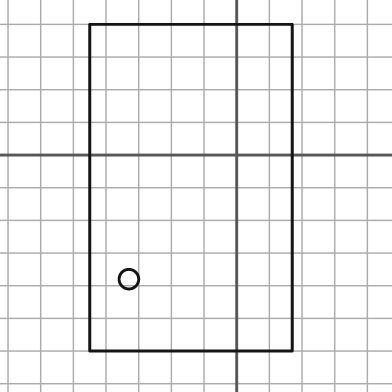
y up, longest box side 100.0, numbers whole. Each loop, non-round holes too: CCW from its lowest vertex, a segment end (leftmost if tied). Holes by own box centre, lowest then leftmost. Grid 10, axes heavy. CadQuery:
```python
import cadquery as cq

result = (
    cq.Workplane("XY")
    .moveTo(-45.0, -60.0)
    .lineTo(17.0, -60.0)
    .lineTo(17.0, 40.0)
    .lineTo(-45.0, 40.0)
    .close()
    .moveTo(-33.0, -38.0)
    .circle(3.0)
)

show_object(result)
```